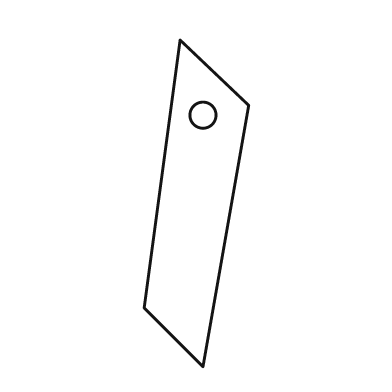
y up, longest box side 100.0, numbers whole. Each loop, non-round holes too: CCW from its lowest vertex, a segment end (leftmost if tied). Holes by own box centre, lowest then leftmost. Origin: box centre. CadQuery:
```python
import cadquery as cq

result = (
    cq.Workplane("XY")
    .moveTo(2.0, -50.0)
    .lineTo(16.0, 30.0)
    .lineTo(-5.0, 50.0)
    .lineTo(-16.0, -32.0)
    .close()
    .moveTo(2.0, 27.0)
    .circle(4.0)
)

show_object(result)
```